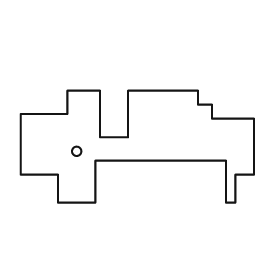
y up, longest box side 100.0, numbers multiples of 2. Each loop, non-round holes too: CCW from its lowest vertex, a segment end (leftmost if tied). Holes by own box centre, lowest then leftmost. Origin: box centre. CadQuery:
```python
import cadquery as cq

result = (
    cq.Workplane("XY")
    .moveTo(-34.0, -24.0)
    .lineTo(-18.0, -24.0)
    .lineTo(-18.0, -6.0)
    .lineTo(38.0, -6.0)
    .lineTo(38.0, -24.0)
    .lineTo(42.0, -24.0)
    .lineTo(42.0, -12.0)
    .lineTo(50.0, -12.0)
    .lineTo(50.0, 12.0)
    .lineTo(32.0, 12.0)
    .lineTo(32.0, 18.0)
    .lineTo(26.0, 18.0)
    .lineTo(26.0, 24.0)
    .lineTo(-4.0, 24.0)
    .lineTo(-4.0, 4.0)
    .lineTo(-16.0, 4.0)
    .lineTo(-16.0, 24.0)
    .lineTo(-30.0, 24.0)
    .lineTo(-30.0, 14.0)
    .lineTo(-50.0, 14.0)
    .lineTo(-50.0, -12.0)
    .lineTo(-34.0, -12.0)
    .close()
    .moveTo(-26.0, -2.0)
    .circle(2.0)
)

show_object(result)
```